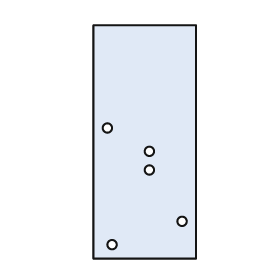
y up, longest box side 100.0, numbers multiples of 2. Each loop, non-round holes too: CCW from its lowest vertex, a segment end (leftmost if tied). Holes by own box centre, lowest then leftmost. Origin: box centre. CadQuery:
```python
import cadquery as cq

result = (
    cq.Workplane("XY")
    .moveTo(-22.0, -50.0)
    .lineTo(22.0, -50.0)
    .lineTo(22.0, 50.0)
    .lineTo(-22.0, 50.0)
    .close()
    .moveTo(-14.0, -44.0)
    .circle(2.0)
    .moveTo(16.0, -34.0)
    .circle(2.0)
    .moveTo(2.0, -12.0)
    .circle(2.0)
    .moveTo(2.0, -4.0)
    .circle(2.0)
    .moveTo(-16.0, 6.0)
    .circle(2.0)
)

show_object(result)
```